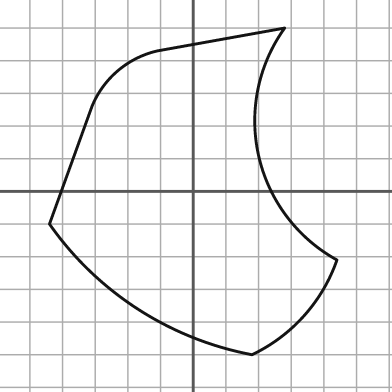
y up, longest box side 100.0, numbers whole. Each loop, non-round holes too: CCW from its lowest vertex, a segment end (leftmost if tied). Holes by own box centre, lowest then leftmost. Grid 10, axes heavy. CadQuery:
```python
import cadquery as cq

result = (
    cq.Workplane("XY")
    .moveTo(18.0, -50.0)
    .threePointArc((34.0, -38.0), (44.0, -21.0))
    .threePointArc((20.0, 11.0), (28.0, 50.0))
    .lineTo(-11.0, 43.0)
    .threePointArc((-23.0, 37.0), (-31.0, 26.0))
    .lineTo(-44.0, -10.0)
    .threePointArc((-17.0, -36.0), (18.0, -50.0))
    .close()
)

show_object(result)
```